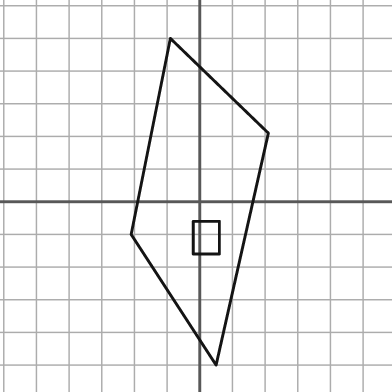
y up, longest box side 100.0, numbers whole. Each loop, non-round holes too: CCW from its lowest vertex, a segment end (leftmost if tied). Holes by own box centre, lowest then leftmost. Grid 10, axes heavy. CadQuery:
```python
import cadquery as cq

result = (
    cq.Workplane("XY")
    .moveTo(5.0, -50.0)
    .lineTo(21.0, 21.0)
    .lineTo(-9.0, 50.0)
    .lineTo(-21.0, -10.0)
    .close()
    .moveTo(-2.0, -16.0)
    .lineTo(6.0, -16.0)
    .lineTo(6.0, -6.0)
    .lineTo(-2.0, -6.0)
    .close()
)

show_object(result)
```